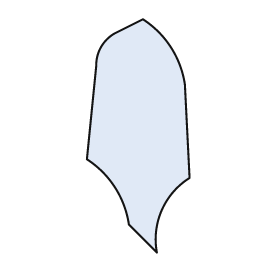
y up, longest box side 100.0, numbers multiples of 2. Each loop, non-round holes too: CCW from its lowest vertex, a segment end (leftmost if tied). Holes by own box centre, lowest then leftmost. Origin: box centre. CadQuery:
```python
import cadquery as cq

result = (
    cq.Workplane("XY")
    .moveTo(8.0, -50.0)
    .threePointArc((10.0, -32.0), (22.0, -18.0))
    .lineTo(20.0, 22.0)
    .threePointArc((14.0, 38.0), (2.0, 50.0))
    .lineTo(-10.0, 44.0)
    .threePointArc((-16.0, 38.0), (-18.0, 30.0))
    .lineTo(-22.0, -10.0)
    .threePointArc((-10.0, -22.0), (-4.0, -38.0))
    .close()
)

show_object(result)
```